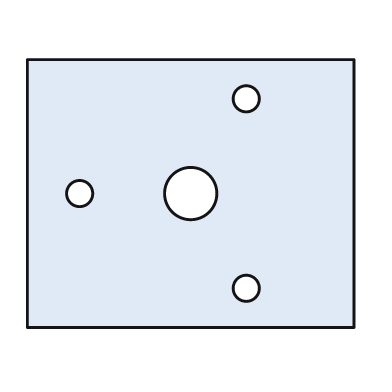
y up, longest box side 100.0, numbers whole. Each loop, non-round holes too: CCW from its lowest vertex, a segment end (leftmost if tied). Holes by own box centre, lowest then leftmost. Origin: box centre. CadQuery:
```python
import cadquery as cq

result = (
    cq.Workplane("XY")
    .moveTo(-50.0, -41.0)
    .lineTo(50.0, -41.0)
    .lineTo(50.0, 41.0)
    .lineTo(-50.0, 41.0)
    .close()
    .moveTo(17.0, -29.0)
    .circle(4.0)
    .moveTo(-34.0, 0.0)
    .circle(4.0)
    .moveTo(0.0, 0.0)
    .circle(8.0)
    .moveTo(17.0, 29.0)
    .circle(4.0)
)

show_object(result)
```